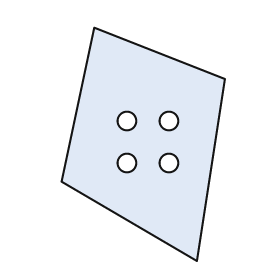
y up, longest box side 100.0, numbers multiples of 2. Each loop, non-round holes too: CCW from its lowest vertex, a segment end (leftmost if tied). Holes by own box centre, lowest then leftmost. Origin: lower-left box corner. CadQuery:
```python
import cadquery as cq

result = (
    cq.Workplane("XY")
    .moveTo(58.0, 0.0)
    .lineTo(70.0, 78.0)
    .lineTo(14.0, 100.0)
    .lineTo(0.0, 34.0)
    .close()
    .moveTo(28.0, 42.0)
    .circle(4.0)
    .moveTo(46.0, 42.0)
    .circle(4.0)
    .moveTo(28.0, 60.0)
    .circle(4.0)
    .moveTo(46.0, 60.0)
    .circle(4.0)
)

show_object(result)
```